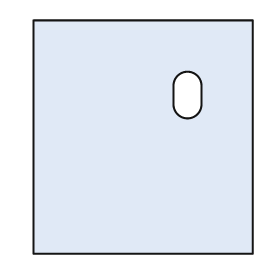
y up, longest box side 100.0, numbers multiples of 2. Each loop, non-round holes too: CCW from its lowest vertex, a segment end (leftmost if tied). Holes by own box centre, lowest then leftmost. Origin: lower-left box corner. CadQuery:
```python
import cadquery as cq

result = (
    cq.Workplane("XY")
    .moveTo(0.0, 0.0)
    .lineTo(94.0, 0.0)
    .lineTo(94.0, 100.0)
    .lineTo(0.0, 100.0)
    .close()
    .moveTo(60.0, 64.0)
    .threePointArc((66.0, 58.0), (72.0, 64.0))
    .lineTo(72.0, 72.0)
    .threePointArc((66.0, 78.0), (60.0, 72.0))
    .close()
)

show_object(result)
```